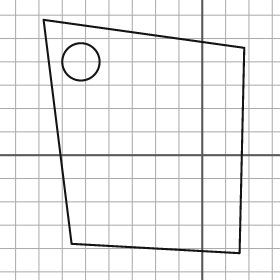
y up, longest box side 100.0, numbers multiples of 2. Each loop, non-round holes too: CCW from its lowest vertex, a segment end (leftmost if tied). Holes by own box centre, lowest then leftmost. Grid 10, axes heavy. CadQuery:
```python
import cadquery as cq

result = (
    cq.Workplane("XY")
    .moveTo(16.0, -42.0)
    .lineTo(18.0, 46.0)
    .lineTo(-68.0, 58.0)
    .lineTo(-56.0, -38.0)
    .close()
    .moveTo(-52.0, 40.0)
    .circle(8.0)
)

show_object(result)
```